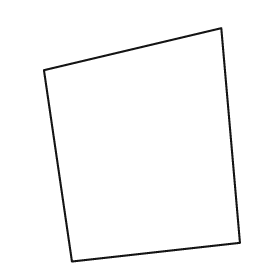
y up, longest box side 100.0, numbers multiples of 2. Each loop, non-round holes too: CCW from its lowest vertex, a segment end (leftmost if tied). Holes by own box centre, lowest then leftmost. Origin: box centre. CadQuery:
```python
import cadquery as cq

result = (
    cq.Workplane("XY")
    .moveTo(-30.0, -50.0)
    .lineTo(42.0, -42.0)
    .lineTo(34.0, 50.0)
    .lineTo(-42.0, 32.0)
    .close()
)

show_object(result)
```